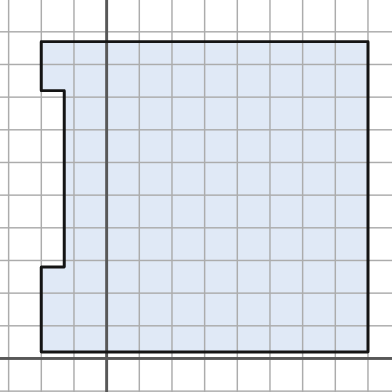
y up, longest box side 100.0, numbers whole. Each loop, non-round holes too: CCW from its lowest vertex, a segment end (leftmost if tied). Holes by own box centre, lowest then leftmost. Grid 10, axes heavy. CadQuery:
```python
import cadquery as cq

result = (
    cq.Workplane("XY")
    .moveTo(-20.0, 2.0)
    .lineTo(80.0, 2.0)
    .lineTo(80.0, 97.0)
    .lineTo(-20.0, 97.0)
    .lineTo(-20.0, 82.0)
    .lineTo(-13.0, 82.0)
    .lineTo(-13.0, 28.0)
    .lineTo(-20.0, 28.0)
    .close()
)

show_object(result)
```